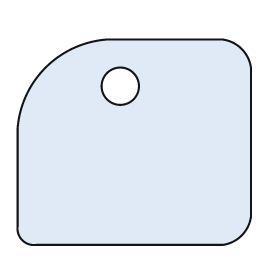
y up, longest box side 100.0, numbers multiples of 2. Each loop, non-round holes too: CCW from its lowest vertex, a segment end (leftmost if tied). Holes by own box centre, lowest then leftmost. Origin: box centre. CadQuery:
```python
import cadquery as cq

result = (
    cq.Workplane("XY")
    .moveTo(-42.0, -44.0)
    .lineTo(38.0, -44.0)
    .threePointArc((46.0, -40.0), (50.0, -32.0))
    .lineTo(50.0, 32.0)
    .threePointArc((46.0, 40.0), (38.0, 44.0))
    .lineTo(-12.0, 44.0)
    .threePointArc((-38.0, 32.0), (-50.0, 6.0))
    .lineTo(-50.0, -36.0)
    .threePointArc((-48.0, -42.0), (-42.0, -44.0))
    .close()
    .moveTo(-6.0, 24.0)
    .circle(8.0)
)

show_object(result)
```